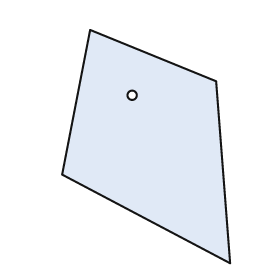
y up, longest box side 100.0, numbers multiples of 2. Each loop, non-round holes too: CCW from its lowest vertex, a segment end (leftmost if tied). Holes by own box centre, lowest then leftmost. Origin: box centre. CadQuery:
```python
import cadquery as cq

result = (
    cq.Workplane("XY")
    .moveTo(36.0, -50.0)
    .lineTo(30.0, 28.0)
    .lineTo(-24.0, 50.0)
    .lineTo(-36.0, -12.0)
    .close()
    .moveTo(-6.0, 22.0)
    .circle(2.0)
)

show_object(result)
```